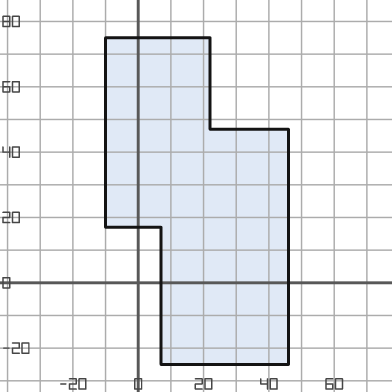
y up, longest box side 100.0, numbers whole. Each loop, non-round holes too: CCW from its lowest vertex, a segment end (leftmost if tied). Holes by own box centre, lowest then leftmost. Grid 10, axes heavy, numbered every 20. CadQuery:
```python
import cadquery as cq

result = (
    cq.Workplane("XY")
    .moveTo(7.0, -25.0)
    .lineTo(46.0, -25.0)
    .lineTo(46.0, 47.0)
    .lineTo(22.0, 47.0)
    .lineTo(22.0, 75.0)
    .lineTo(-10.0, 75.0)
    .lineTo(-10.0, 17.0)
    .lineTo(7.0, 17.0)
    .close()
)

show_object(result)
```